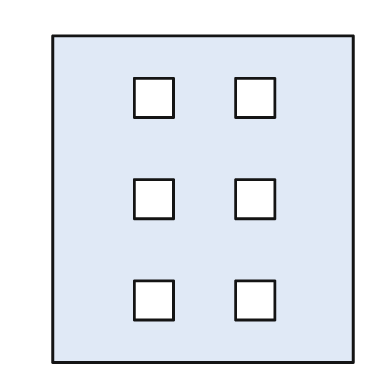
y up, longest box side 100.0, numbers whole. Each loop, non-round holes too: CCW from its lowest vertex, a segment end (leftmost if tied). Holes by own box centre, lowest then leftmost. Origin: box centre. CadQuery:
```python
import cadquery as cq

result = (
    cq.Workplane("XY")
    .moveTo(-46.0, -50.0)
    .lineTo(46.0, -50.0)
    .lineTo(46.0, 50.0)
    .lineTo(-46.0, 50.0)
    .close()
    .moveTo(-21.0, -37.0)
    .lineTo(-9.0, -37.0)
    .lineTo(-9.0, -25.0)
    .lineTo(-21.0, -25.0)
    .close()
    .moveTo(10.0, -37.0)
    .lineTo(22.0, -37.0)
    .lineTo(22.0, -25.0)
    .lineTo(10.0, -25.0)
    .close()
    .moveTo(-21.0, -6.0)
    .lineTo(-9.0, -6.0)
    .lineTo(-9.0, 6.0)
    .lineTo(-21.0, 6.0)
    .close()
    .moveTo(10.0, -6.0)
    .lineTo(22.0, -6.0)
    .lineTo(22.0, 6.0)
    .lineTo(10.0, 6.0)
    .close()
    .moveTo(-21.0, 25.0)
    .lineTo(-9.0, 25.0)
    .lineTo(-9.0, 37.0)
    .lineTo(-21.0, 37.0)
    .close()
    .moveTo(10.0, 25.0)
    .lineTo(22.0, 25.0)
    .lineTo(22.0, 37.0)
    .lineTo(10.0, 37.0)
    .close()
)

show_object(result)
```